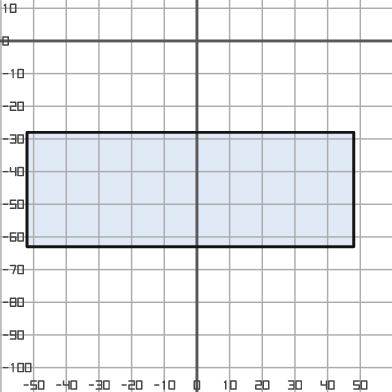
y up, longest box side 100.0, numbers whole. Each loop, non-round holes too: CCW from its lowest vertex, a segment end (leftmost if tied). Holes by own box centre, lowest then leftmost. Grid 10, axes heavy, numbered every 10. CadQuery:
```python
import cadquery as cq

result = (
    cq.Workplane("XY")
    .moveTo(-52.0, -63.0)
    .lineTo(48.0, -63.0)
    .lineTo(48.0, -28.0)
    .lineTo(-52.0, -28.0)
    .close()
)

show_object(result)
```